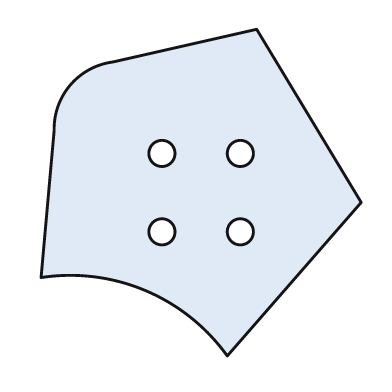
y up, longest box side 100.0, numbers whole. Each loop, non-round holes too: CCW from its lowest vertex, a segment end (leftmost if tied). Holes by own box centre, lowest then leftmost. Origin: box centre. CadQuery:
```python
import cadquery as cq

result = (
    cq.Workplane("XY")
    .moveTo(8.0, -50.0)
    .lineTo(49.0, -3.0)
    .lineTo(17.0, 50.0)
    .lineTo(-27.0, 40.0)
    .threePointArc((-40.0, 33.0), (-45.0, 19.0))
    .lineTo(-49.0, -26.0)
    .threePointArc((-17.0, -30.0), (8.0, -50.0))
    .close()
    .moveTo(-12.0, -12.0)
    .circle(4.0)
    .moveTo(12.0, -12.0)
    .circle(4.0)
    .moveTo(-12.0, 12.0)
    .circle(4.0)
    .moveTo(12.0, 12.0)
    .circle(4.0)
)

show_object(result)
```